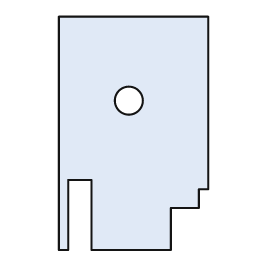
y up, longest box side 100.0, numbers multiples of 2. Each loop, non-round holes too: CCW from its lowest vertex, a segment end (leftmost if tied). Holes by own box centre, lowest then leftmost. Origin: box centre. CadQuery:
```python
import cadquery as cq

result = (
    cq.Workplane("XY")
    .moveTo(-32.0, -50.0)
    .lineTo(-28.0, -50.0)
    .lineTo(-28.0, -20.0)
    .lineTo(-18.0, -20.0)
    .lineTo(-18.0, -50.0)
    .lineTo(16.0, -50.0)
    .lineTo(16.0, -32.0)
    .lineTo(28.0, -32.0)
    .lineTo(28.0, -24.0)
    .lineTo(32.0, -24.0)
    .lineTo(32.0, 50.0)
    .lineTo(-32.0, 50.0)
    .close()
    .moveTo(-2.0, 14.0)
    .circle(6.0)
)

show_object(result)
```